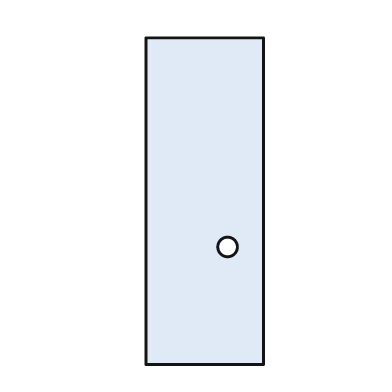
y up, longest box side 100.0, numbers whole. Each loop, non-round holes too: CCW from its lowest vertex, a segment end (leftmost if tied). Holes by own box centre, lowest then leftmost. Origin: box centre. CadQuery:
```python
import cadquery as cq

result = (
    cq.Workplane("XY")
    .moveTo(-18.0, -50.0)
    .lineTo(18.0, -50.0)
    .lineTo(18.0, 50.0)
    .lineTo(-18.0, 50.0)
    .close()
    .moveTo(7.0, -14.0)
    .circle(3.0)
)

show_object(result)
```